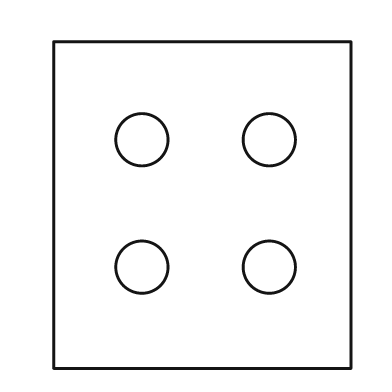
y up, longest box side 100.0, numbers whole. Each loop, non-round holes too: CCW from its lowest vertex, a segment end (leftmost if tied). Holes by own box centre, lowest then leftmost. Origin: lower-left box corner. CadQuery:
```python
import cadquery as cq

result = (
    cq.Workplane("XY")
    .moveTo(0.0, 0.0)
    .lineTo(91.0, 0.0)
    .lineTo(91.0, 100.0)
    .lineTo(0.0, 100.0)
    .close()
    .moveTo(27.0, 31.0)
    .circle(8.0)
    .moveTo(66.0, 31.0)
    .circle(8.0)
    .moveTo(27.0, 70.0)
    .circle(8.0)
    .moveTo(66.0, 70.0)
    .circle(8.0)
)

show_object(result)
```